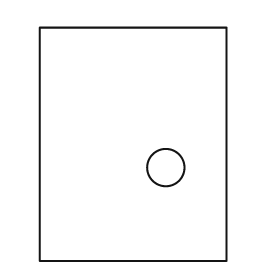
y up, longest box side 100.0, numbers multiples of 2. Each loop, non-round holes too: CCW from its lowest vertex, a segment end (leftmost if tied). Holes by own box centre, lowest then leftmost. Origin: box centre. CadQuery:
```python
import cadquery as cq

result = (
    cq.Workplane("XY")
    .moveTo(-40.0, -50.0)
    .lineTo(40.0, -50.0)
    .lineTo(40.0, 50.0)
    .lineTo(-40.0, 50.0)
    .close()
    .moveTo(14.0, -10.0)
    .circle(8.0)
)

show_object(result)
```